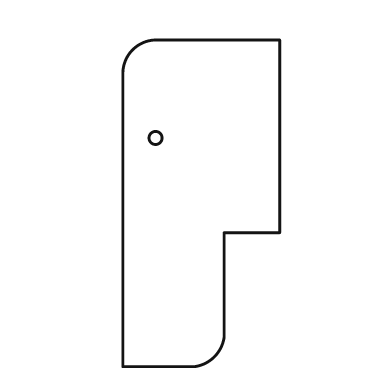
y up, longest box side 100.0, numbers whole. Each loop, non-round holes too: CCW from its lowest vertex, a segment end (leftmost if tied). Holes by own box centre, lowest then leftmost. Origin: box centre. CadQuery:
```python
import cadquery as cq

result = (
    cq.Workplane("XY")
    .moveTo(-24.0, -50.0)
    .lineTo(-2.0, -50.0)
    .threePointArc((4.0, -47.0), (7.0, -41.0))
    .lineTo(7.0, -9.0)
    .lineTo(24.0, -9.0)
    .lineTo(24.0, 50.0)
    .lineTo(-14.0, 50.0)
    .threePointArc((-21.0, 47.0), (-24.0, 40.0))
    .close()
    .moveTo(-14.0, 20.0)
    .circle(2.0)
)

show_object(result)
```